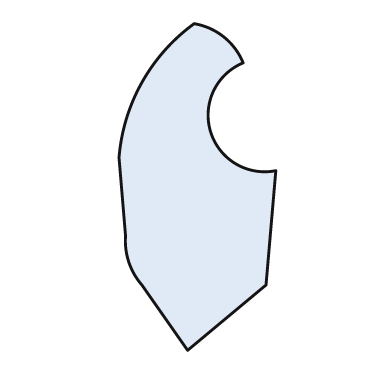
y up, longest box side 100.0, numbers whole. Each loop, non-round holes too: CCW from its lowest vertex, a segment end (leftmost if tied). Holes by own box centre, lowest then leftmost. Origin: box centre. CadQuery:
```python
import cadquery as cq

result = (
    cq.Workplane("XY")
    .moveTo(-3.0, -50.0)
    .lineTo(21.0, -30.0)
    .lineTo(24.0, 5.0)
    .threePointArc((4.0, 17.0), (14.0, 38.0))
    .threePointArc((8.0, 46.0), (-1.0, 50.0))
    .threePointArc((-17.0, 32.0), (-24.0, 9.0))
    .lineTo(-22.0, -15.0)
    .threePointArc((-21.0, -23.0), (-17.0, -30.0))
    .close()
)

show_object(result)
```